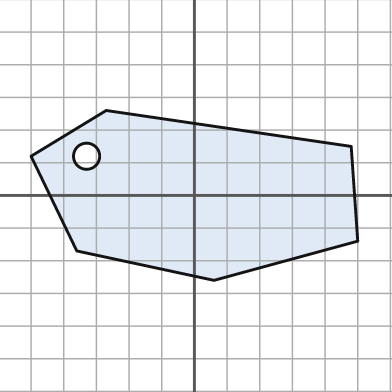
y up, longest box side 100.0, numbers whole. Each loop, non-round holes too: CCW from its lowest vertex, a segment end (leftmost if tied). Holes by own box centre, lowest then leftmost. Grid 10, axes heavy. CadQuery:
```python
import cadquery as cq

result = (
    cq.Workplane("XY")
    .moveTo(6.0, -26.0)
    .lineTo(50.0, -14.0)
    .lineTo(48.0, 15.0)
    .lineTo(-27.0, 26.0)
    .lineTo(-50.0, 12.0)
    .lineTo(-36.0, -17.0)
    .close()
    .moveTo(-33.0, 12.0)
    .circle(4.0)
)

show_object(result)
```